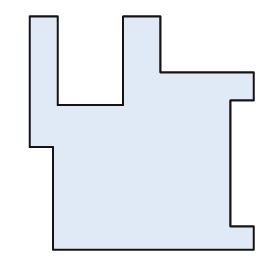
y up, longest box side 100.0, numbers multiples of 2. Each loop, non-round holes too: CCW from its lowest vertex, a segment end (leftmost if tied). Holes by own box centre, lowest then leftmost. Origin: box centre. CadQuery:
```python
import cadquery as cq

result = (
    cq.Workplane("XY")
    .moveTo(-38.0, -50.0)
    .lineTo(48.0, -50.0)
    .lineTo(48.0, -40.0)
    .lineTo(38.0, -40.0)
    .lineTo(38.0, 14.0)
    .lineTo(48.0, 14.0)
    .lineTo(48.0, 26.0)
    .lineTo(8.0, 26.0)
    .lineTo(8.0, 50.0)
    .lineTo(-8.0, 50.0)
    .lineTo(-8.0, 12.0)
    .lineTo(-36.0, 12.0)
    .lineTo(-36.0, 50.0)
    .lineTo(-48.0, 50.0)
    .lineTo(-48.0, -6.0)
    .lineTo(-38.0, -6.0)
    .close()
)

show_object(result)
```